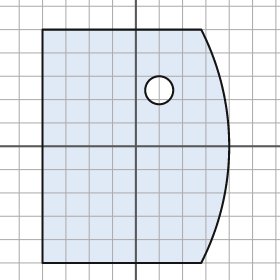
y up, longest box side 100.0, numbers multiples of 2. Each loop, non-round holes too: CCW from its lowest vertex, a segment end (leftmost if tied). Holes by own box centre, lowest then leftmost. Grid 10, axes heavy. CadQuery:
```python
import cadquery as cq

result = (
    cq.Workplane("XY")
    .moveTo(-40.0, -50.0)
    .lineTo(28.0, -50.0)
    .threePointArc((40.0, 0.0), (28.0, 50.0))
    .lineTo(-40.0, 50.0)
    .close()
    .moveTo(10.0, 24.0)
    .circle(6.0)
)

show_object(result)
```